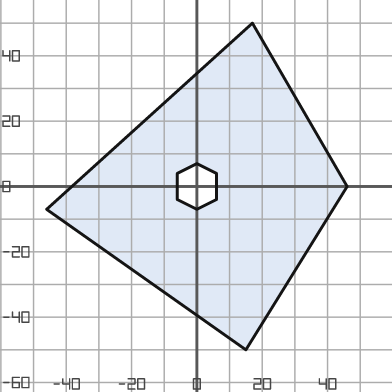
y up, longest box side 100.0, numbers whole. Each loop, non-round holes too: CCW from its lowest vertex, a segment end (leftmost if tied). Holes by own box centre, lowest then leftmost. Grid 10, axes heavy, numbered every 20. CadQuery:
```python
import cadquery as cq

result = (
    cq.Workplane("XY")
    .moveTo(15.0, -50.0)
    .lineTo(46.0, 0.0)
    .lineTo(17.0, 50.0)
    .lineTo(-46.0, -7.0)
    .close()
    .moveTo(0.0, -7.0)
    .lineTo(6.0, -4.0)
    .lineTo(6.0, 4.0)
    .lineTo(0.0, 7.0)
    .lineTo(-6.0, 4.0)
    .lineTo(-6.0, -4.0)
    .close()
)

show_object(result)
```